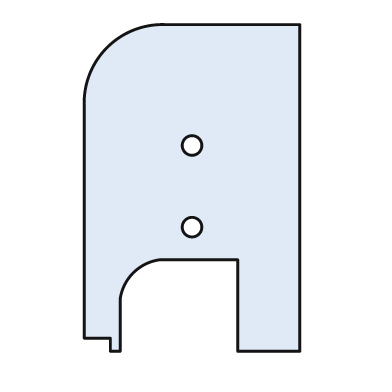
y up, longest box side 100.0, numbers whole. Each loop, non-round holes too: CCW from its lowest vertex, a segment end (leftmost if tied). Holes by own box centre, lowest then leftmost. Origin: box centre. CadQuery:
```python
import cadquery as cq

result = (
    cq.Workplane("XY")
    .moveTo(-25.0, -50.0)
    .lineTo(-22.0, -50.0)
    .lineTo(-22.0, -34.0)
    .threePointArc((-18.0, -26.0), (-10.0, -22.0))
    .lineTo(14.0, -22.0)
    .lineTo(14.0, -50.0)
    .lineTo(33.0, -50.0)
    .lineTo(33.0, 50.0)
    .lineTo(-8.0, 50.0)
    .threePointArc((-26.0, 43.0), (-33.0, 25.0))
    .lineTo(-33.0, -46.0)
    .lineTo(-25.0, -46.0)
    .close()
    .moveTo(0.0, -12.0)
    .circle(3.0)
    .moveTo(0.0, 13.0)
    .circle(3.0)
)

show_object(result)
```